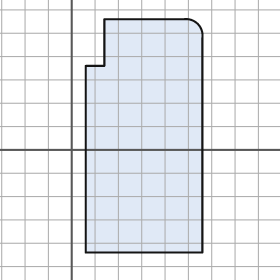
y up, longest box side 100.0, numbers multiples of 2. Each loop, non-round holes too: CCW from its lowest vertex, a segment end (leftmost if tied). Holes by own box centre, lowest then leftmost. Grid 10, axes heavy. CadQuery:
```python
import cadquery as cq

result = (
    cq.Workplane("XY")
    .moveTo(6.0, -44.0)
    .lineTo(56.0, -44.0)
    .lineTo(56.0, 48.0)
    .threePointArc((54.0, 54.0), (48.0, 56.0))
    .lineTo(14.0, 56.0)
    .lineTo(14.0, 36.0)
    .lineTo(6.0, 36.0)
    .close()
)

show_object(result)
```